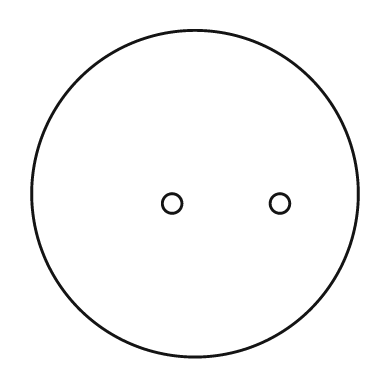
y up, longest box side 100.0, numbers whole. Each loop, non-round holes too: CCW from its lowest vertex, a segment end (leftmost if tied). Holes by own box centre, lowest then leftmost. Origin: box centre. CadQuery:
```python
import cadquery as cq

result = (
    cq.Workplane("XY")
    .moveTo(0.0, 0.0)
    .circle(50.0)
    .moveTo(-7.0, -3.0)
    .circle(3.0)
    .moveTo(26.0, -3.0)
    .circle(3.0)
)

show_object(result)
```